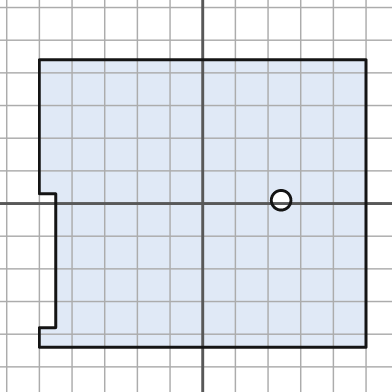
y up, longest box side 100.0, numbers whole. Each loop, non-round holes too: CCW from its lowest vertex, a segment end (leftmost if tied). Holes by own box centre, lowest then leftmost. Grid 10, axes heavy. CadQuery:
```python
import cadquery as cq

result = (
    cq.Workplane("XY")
    .moveTo(-50.0, -44.0)
    .lineTo(50.0, -44.0)
    .lineTo(50.0, 44.0)
    .lineTo(-50.0, 44.0)
    .lineTo(-50.0, 3.0)
    .lineTo(-45.0, 3.0)
    .lineTo(-45.0, -38.0)
    .lineTo(-50.0, -38.0)
    .close()
    .moveTo(24.0, 1.0)
    .circle(3.0)
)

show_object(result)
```